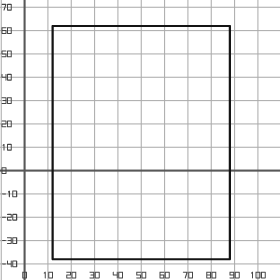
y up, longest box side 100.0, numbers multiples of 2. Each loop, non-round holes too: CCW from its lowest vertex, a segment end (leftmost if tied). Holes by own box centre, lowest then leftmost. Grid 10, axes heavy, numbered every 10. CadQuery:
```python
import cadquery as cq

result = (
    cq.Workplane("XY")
    .moveTo(12.0, -38.0)
    .lineTo(88.0, -38.0)
    .lineTo(88.0, 62.0)
    .lineTo(12.0, 62.0)
    .close()
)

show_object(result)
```